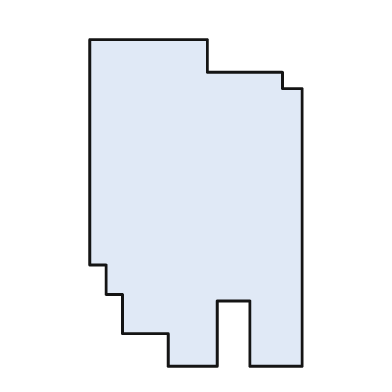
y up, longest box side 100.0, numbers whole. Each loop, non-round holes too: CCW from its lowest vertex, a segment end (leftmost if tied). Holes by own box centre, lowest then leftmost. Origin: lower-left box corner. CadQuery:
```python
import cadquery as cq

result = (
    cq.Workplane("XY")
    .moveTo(24.0, 0.0)
    .lineTo(39.0, 0.0)
    .lineTo(39.0, 20.0)
    .lineTo(49.0, 20.0)
    .lineTo(49.0, 0.0)
    .lineTo(65.0, 0.0)
    .lineTo(65.0, 85.0)
    .lineTo(59.0, 85.0)
    .lineTo(59.0, 90.0)
    .lineTo(36.0, 90.0)
    .lineTo(36.0, 100.0)
    .lineTo(0.0, 100.0)
    .lineTo(0.0, 31.0)
    .lineTo(5.0, 31.0)
    .lineTo(5.0, 22.0)
    .lineTo(10.0, 22.0)
    .lineTo(10.0, 10.0)
    .lineTo(24.0, 10.0)
    .close()
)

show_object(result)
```